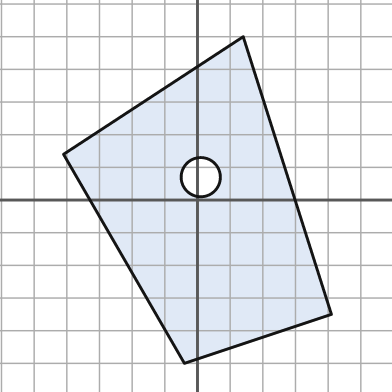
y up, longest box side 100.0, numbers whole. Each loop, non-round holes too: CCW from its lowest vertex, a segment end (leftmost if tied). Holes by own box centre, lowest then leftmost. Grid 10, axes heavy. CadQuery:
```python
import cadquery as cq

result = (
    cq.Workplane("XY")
    .moveTo(-4.0, -50.0)
    .lineTo(41.0, -35.0)
    .lineTo(14.0, 50.0)
    .lineTo(-41.0, 14.0)
    .close()
    .moveTo(1.0, 7.0)
    .circle(6.0)
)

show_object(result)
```